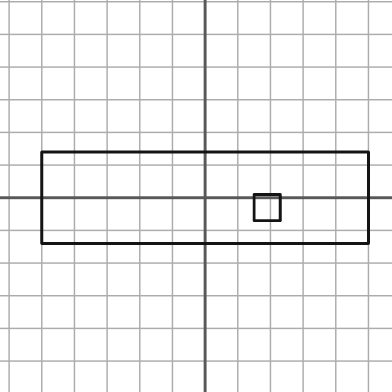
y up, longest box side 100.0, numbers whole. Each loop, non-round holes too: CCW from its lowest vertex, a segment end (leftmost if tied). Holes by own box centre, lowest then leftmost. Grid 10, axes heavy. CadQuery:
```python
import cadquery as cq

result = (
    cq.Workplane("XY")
    .moveTo(-50.0, -14.0)
    .lineTo(50.0, -14.0)
    .lineTo(50.0, 14.0)
    .lineTo(-50.0, 14.0)
    .close()
    .moveTo(15.0, -7.0)
    .lineTo(23.0, -7.0)
    .lineTo(23.0, 1.0)
    .lineTo(15.0, 1.0)
    .close()
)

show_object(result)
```